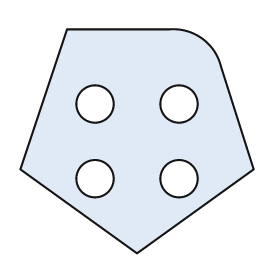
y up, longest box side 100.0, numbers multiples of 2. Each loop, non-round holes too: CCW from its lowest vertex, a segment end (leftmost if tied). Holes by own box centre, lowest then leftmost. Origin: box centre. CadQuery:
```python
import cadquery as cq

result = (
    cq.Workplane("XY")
    .moveTo(0.0, -48.0)
    .lineTo(50.0, -12.0)
    .lineTo(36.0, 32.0)
    .threePointArc((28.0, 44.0), (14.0, 48.0))
    .lineTo(-30.0, 48.0)
    .lineTo(-50.0, -12.0)
    .close()
    .moveTo(-18.0, -16.0)
    .circle(8.0)
    .moveTo(18.0, -16.0)
    .circle(8.0)
    .moveTo(-18.0, 16.0)
    .circle(8.0)
    .moveTo(18.0, 16.0)
    .circle(8.0)
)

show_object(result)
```